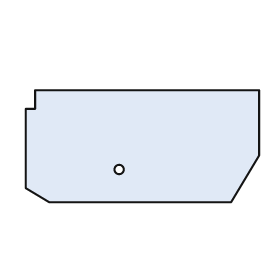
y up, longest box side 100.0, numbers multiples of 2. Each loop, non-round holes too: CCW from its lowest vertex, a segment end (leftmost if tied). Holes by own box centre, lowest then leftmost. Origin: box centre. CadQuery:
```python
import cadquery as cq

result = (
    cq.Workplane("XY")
    .moveTo(-40.0, -24.0)
    .lineTo(38.0, -24.0)
    .lineTo(50.0, -4.0)
    .lineTo(50.0, 24.0)
    .lineTo(-46.0, 24.0)
    .lineTo(-46.0, 16.0)
    .lineTo(-50.0, 16.0)
    .lineTo(-50.0, -18.0)
    .close()
    .moveTo(-10.0, -10.0)
    .circle(2.0)
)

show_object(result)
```